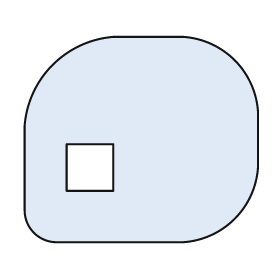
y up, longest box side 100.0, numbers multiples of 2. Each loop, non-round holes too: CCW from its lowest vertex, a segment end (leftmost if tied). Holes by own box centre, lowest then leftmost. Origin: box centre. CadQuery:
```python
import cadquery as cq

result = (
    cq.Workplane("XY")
    .moveTo(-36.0, -44.0)
    .lineTo(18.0, -44.0)
    .threePointArc((40.0, -34.0), (50.0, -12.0))
    .lineTo(50.0, 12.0)
    .threePointArc((40.0, 34.0), (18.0, 44.0))
    .lineTo(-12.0, 44.0)
    .threePointArc((-38.0, 32.0), (-50.0, 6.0))
    .lineTo(-50.0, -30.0)
    .threePointArc((-46.0, -40.0), (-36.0, -44.0))
    .close()
    .moveTo(-32.0, -22.0)
    .lineTo(-12.0, -22.0)
    .lineTo(-12.0, -2.0)
    .lineTo(-32.0, -2.0)
    .close()
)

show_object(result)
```